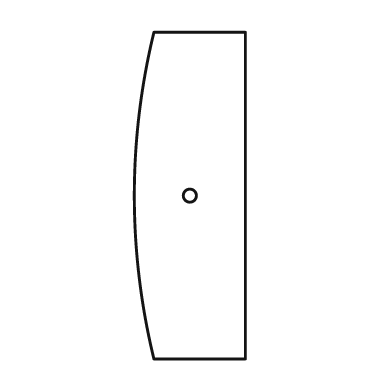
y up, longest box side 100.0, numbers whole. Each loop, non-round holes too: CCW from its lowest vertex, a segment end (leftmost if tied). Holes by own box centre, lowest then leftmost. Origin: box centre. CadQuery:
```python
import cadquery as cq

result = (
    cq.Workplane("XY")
    .moveTo(-11.0, -50.0)
    .lineTo(17.0, -50.0)
    .lineTo(17.0, 50.0)
    .lineTo(-11.0, 50.0)
    .threePointArc((-17.0, 0.0), (-11.0, -50.0))
    .close()
    .moveTo(0.0, 0.0)
    .circle(2.0)
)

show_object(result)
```